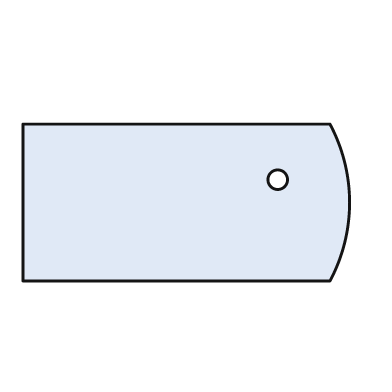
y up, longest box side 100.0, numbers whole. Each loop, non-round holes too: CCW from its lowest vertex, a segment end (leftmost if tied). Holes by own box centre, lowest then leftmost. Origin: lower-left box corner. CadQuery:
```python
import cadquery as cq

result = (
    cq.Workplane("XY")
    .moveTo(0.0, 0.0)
    .lineTo(94.0, 0.0)
    .threePointArc((100.0, 24.0), (94.0, 48.0))
    .lineTo(0.0, 48.0)
    .close()
    .moveTo(78.0, 31.0)
    .circle(3.0)
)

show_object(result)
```